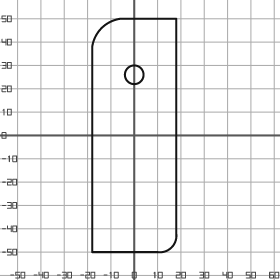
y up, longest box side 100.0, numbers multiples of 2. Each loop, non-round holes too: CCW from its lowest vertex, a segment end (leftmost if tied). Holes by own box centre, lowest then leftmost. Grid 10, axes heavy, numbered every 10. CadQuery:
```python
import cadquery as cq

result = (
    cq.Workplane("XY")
    .moveTo(-18.0, -50.0)
    .lineTo(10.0, -50.0)
    .threePointArc((16.0, -48.0), (18.0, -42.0))
    .lineTo(18.0, 50.0)
    .lineTo(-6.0, 50.0)
    .threePointArc((-14.0, 46.0), (-18.0, 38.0))
    .close()
    .moveTo(0.0, 26.0)
    .circle(4.0)
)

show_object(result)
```